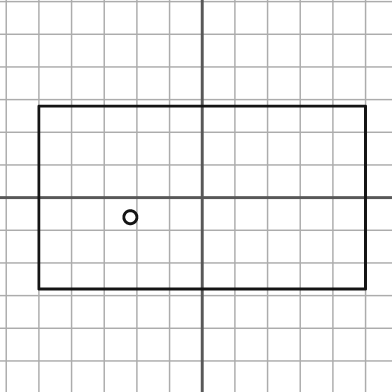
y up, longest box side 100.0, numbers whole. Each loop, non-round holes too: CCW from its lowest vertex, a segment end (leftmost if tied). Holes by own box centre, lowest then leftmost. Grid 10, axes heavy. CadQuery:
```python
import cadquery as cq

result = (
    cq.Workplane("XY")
    .moveTo(-50.0, -28.0)
    .lineTo(50.0, -28.0)
    .lineTo(50.0, 28.0)
    .lineTo(-50.0, 28.0)
    .close()
    .moveTo(-22.0, -6.0)
    .circle(2.0)
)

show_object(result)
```